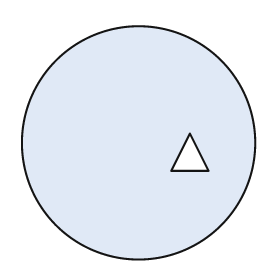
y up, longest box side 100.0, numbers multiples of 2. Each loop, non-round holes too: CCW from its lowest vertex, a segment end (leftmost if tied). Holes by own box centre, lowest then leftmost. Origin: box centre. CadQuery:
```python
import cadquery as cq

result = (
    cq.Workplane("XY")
    .moveTo(0.0, 0.0)
    .circle(50.0)
    .moveTo(14.0, -12.0)
    .lineTo(30.0, -12.0)
    .lineTo(22.0, 4.0)
    .close()
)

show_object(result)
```